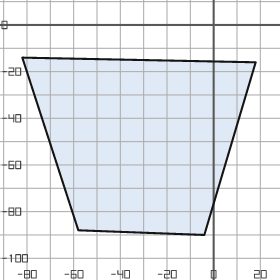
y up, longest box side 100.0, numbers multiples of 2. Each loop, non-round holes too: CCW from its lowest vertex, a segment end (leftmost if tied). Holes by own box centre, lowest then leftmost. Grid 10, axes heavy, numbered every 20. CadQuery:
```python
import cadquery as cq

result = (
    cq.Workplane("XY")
    .moveTo(-4.0, -90.0)
    .lineTo(18.0, -16.0)
    .lineTo(-82.0, -14.0)
    .lineTo(-58.0, -88.0)
    .close()
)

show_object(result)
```